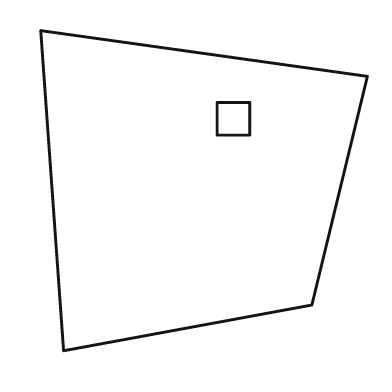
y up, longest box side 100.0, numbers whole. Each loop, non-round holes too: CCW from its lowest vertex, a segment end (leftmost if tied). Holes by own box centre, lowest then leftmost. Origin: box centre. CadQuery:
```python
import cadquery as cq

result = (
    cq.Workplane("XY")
    .moveTo(-43.0, -49.0)
    .lineTo(33.0, -35.0)
    .lineTo(50.0, 35.0)
    .lineTo(-50.0, 49.0)
    .close()
    .moveTo(4.0, 17.0)
    .lineTo(14.0, 17.0)
    .lineTo(14.0, 27.0)
    .lineTo(4.0, 27.0)
    .close()
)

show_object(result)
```